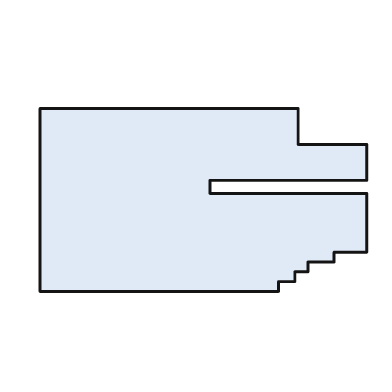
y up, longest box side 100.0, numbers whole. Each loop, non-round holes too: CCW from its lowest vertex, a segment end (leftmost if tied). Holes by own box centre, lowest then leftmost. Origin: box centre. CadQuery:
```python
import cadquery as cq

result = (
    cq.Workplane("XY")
    .moveTo(-50.0, -28.0)
    .lineTo(23.0, -28.0)
    .lineTo(23.0, -25.0)
    .lineTo(28.0, -25.0)
    .lineTo(28.0, -22.0)
    .lineTo(32.0, -22.0)
    .lineTo(32.0, -19.0)
    .lineTo(40.0, -19.0)
    .lineTo(40.0, -16.0)
    .lineTo(50.0, -16.0)
    .lineTo(50.0, 2.0)
    .lineTo(2.0, 2.0)
    .lineTo(2.0, 6.0)
    .lineTo(50.0, 6.0)
    .lineTo(50.0, 17.0)
    .lineTo(29.0, 17.0)
    .lineTo(29.0, 28.0)
    .lineTo(-50.0, 28.0)
    .close()
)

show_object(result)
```